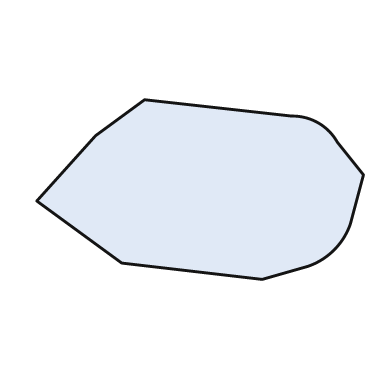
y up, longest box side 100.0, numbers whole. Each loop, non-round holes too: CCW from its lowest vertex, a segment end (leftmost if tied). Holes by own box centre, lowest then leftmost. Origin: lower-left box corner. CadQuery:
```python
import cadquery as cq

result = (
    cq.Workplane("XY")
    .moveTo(69.0, 0.0)
    .lineTo(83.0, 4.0)
    .threePointArc((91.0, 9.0), (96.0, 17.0))
    .lineTo(100.0, 32.0)
    .lineTo(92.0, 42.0)
    .threePointArc((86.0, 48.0), (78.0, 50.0))
    .lineTo(33.0, 55.0)
    .lineTo(18.0, 44.0)
    .lineTo(0.0, 24.0)
    .lineTo(26.0, 5.0)
    .close()
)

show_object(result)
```